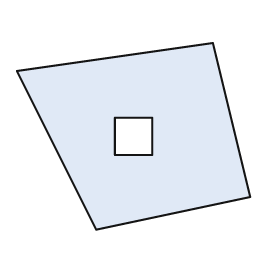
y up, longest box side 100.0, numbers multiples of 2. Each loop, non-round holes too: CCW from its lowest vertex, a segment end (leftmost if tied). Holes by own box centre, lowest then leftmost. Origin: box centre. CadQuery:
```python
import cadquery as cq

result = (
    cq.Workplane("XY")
    .moveTo(-16.0, -40.0)
    .lineTo(50.0, -26.0)
    .lineTo(34.0, 40.0)
    .lineTo(-50.0, 28.0)
    .close()
    .moveTo(-8.0, -8.0)
    .lineTo(8.0, -8.0)
    .lineTo(8.0, 8.0)
    .lineTo(-8.0, 8.0)
    .close()
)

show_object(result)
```